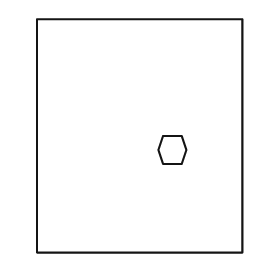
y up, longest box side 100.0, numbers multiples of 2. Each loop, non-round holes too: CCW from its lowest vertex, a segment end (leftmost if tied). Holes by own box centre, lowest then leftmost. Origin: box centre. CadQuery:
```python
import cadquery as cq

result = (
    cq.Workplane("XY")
    .moveTo(-44.0, -50.0)
    .lineTo(44.0, -50.0)
    .lineTo(44.0, 50.0)
    .lineTo(-44.0, 50.0)
    .close()
    .moveTo(10.0, -12.0)
    .lineTo(18.0, -12.0)
    .lineTo(20.0, -6.0)
    .lineTo(18.0, 0.0)
    .lineTo(10.0, 0.0)
    .lineTo(8.0, -6.0)
    .close()
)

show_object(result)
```